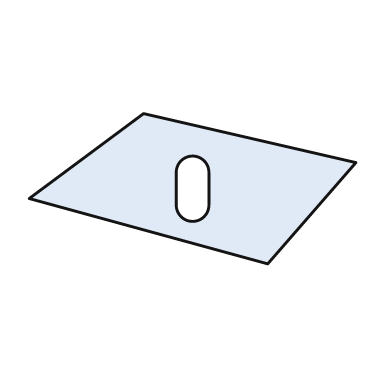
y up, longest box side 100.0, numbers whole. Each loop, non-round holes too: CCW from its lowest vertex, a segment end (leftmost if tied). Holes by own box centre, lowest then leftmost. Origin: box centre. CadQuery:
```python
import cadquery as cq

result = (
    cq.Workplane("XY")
    .moveTo(23.0, -23.0)
    .lineTo(50.0, 8.0)
    .lineTo(-15.0, 23.0)
    .lineTo(-50.0, -3.0)
    .close()
    .moveTo(-5.0, -5.0)
    .threePointArc((0.0, -10.0), (5.0, -5.0))
    .lineTo(5.0, 5.0)
    .threePointArc((0.0, 10.0), (-5.0, 5.0))
    .close()
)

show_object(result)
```